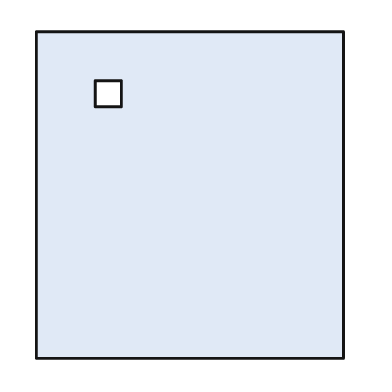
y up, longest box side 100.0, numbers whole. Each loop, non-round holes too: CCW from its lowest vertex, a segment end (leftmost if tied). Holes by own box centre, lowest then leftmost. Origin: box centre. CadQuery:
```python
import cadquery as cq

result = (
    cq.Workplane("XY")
    .moveTo(-47.0, -50.0)
    .lineTo(47.0, -50.0)
    .lineTo(47.0, 50.0)
    .lineTo(-47.0, 50.0)
    .close()
    .moveTo(-29.0, 27.0)
    .lineTo(-21.0, 27.0)
    .lineTo(-21.0, 35.0)
    .lineTo(-29.0, 35.0)
    .close()
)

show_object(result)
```